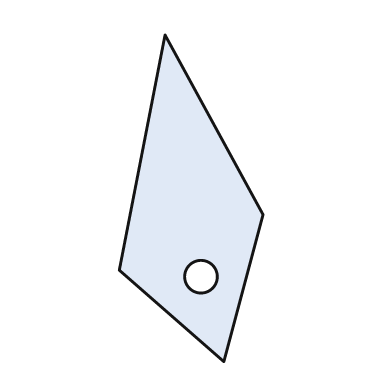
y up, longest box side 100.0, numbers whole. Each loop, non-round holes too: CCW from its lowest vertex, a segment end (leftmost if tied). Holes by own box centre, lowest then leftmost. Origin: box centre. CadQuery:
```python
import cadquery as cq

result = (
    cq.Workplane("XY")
    .moveTo(10.0, -50.0)
    .lineTo(22.0, -5.0)
    .lineTo(-8.0, 50.0)
    .lineTo(-22.0, -22.0)
    .close()
    .moveTo(3.0, -24.0)
    .circle(5.0)
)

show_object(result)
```